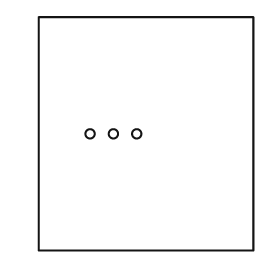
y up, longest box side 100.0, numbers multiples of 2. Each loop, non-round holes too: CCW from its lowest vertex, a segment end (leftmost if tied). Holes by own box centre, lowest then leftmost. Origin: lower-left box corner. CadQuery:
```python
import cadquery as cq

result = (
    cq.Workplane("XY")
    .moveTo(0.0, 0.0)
    .lineTo(92.0, 0.0)
    .lineTo(92.0, 100.0)
    .lineTo(0.0, 100.0)
    .close()
    .moveTo(22.0, 50.0)
    .circle(2.0)
    .moveTo(32.0, 50.0)
    .circle(2.0)
    .moveTo(42.0, 50.0)
    .circle(2.0)
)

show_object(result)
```